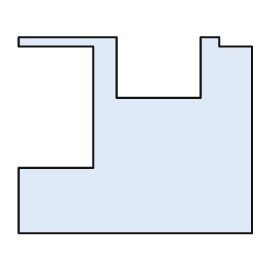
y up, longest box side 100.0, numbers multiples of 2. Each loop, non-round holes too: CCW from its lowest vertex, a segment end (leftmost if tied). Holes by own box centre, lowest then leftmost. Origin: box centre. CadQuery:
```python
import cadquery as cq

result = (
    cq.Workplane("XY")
    .moveTo(-50.0, -42.0)
    .lineTo(50.0, -42.0)
    .lineTo(50.0, 38.0)
    .lineTo(36.0, 38.0)
    .lineTo(36.0, 42.0)
    .lineTo(28.0, 42.0)
    .lineTo(28.0, 16.0)
    .lineTo(-8.0, 16.0)
    .lineTo(-8.0, 42.0)
    .lineTo(-50.0, 42.0)
    .lineTo(-50.0, 38.0)
    .lineTo(-18.0, 38.0)
    .lineTo(-18.0, -14.0)
    .lineTo(-50.0, -14.0)
    .close()
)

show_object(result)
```